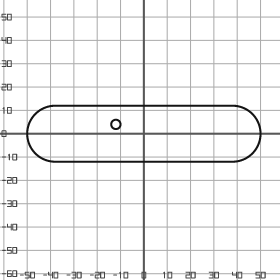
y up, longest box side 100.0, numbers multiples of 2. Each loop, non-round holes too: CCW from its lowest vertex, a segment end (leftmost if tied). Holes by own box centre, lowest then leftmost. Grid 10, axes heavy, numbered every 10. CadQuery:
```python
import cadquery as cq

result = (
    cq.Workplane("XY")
    .moveTo(-38.0, -12.0)
    .lineTo(38.0, -12.0)
    .threePointArc((50.0, 0.0), (38.0, 12.0))
    .lineTo(-38.0, 12.0)
    .threePointArc((-50.0, 0.0), (-38.0, -12.0))
    .close()
    .moveTo(-12.0, 4.0)
    .circle(2.0)
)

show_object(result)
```